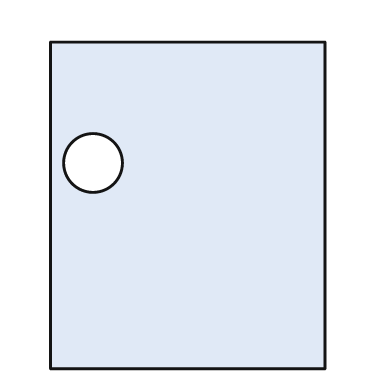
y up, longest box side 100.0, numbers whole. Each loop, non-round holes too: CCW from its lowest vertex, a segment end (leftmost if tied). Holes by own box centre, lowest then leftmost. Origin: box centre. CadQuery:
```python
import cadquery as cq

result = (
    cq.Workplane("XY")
    .moveTo(-42.0, -50.0)
    .lineTo(42.0, -50.0)
    .lineTo(42.0, 50.0)
    .lineTo(-42.0, 50.0)
    .close()
    .moveTo(-29.0, 13.0)
    .circle(9.0)
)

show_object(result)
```